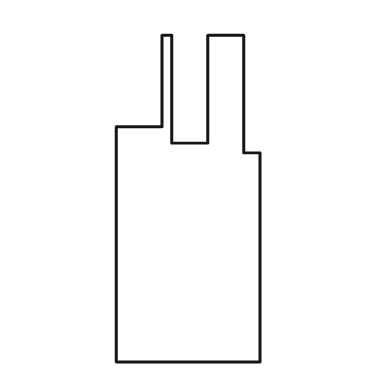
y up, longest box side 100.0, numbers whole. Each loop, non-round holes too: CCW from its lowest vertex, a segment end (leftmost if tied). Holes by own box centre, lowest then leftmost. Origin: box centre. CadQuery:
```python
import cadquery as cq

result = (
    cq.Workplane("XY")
    .moveTo(-22.0, -50.0)
    .lineTo(22.0, -50.0)
    .lineTo(22.0, 14.0)
    .lineTo(17.0, 14.0)
    .lineTo(17.0, 50.0)
    .lineTo(6.0, 50.0)
    .lineTo(6.0, 17.0)
    .lineTo(-5.0, 17.0)
    .lineTo(-5.0, 50.0)
    .lineTo(-8.0, 50.0)
    .lineTo(-8.0, 22.0)
    .lineTo(-22.0, 22.0)
    .close()
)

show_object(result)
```